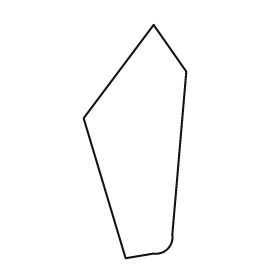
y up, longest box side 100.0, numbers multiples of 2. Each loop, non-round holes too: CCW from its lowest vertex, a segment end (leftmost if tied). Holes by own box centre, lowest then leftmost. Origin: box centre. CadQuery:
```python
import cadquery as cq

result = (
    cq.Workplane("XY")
    .moveTo(-4.0, -50.0)
    .lineTo(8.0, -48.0)
    .threePointArc((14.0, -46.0), (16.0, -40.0))
    .lineTo(22.0, 30.0)
    .lineTo(8.0, 50.0)
    .lineTo(-22.0, 10.0)
    .close()
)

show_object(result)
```